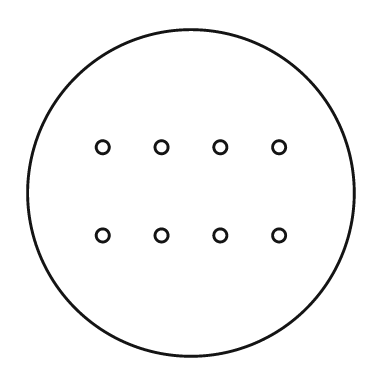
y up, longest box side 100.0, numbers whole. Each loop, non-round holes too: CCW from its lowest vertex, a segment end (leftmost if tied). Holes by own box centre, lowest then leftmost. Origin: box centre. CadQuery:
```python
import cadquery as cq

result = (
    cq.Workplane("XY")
    .moveTo(0.0, 0.0)
    .circle(50.0)
    .moveTo(-27.0, -13.0)
    .circle(2.0)
    .moveTo(-9.0, -13.0)
    .circle(2.0)
    .moveTo(9.0, -13.0)
    .circle(2.0)
    .moveTo(27.0, -13.0)
    .circle(2.0)
    .moveTo(-27.0, 14.0)
    .circle(2.0)
    .moveTo(-9.0, 14.0)
    .circle(2.0)
    .moveTo(9.0, 14.0)
    .circle(2.0)
    .moveTo(27.0, 14.0)
    .circle(2.0)
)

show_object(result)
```